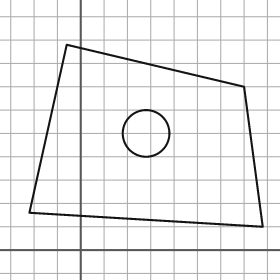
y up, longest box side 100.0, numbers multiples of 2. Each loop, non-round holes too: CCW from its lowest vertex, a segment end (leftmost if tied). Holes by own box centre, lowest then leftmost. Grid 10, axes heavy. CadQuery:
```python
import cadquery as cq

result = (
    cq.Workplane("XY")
    .moveTo(78.0, 10.0)
    .lineTo(70.0, 70.0)
    .lineTo(-6.0, 88.0)
    .lineTo(-22.0, 16.0)
    .close()
    .moveTo(28.0, 50.0)
    .circle(10.0)
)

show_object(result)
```